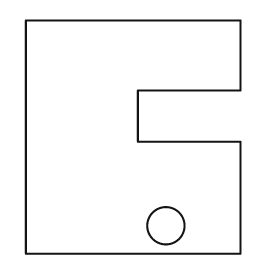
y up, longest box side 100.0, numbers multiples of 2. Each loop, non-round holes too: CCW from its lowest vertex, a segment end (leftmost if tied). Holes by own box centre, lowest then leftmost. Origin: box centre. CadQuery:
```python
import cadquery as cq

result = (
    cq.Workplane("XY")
    .moveTo(-46.0, -50.0)
    .lineTo(46.0, -50.0)
    .lineTo(46.0, -2.0)
    .lineTo(2.0, -2.0)
    .lineTo(2.0, 20.0)
    .lineTo(46.0, 20.0)
    .lineTo(46.0, 50.0)
    .lineTo(-46.0, 50.0)
    .close()
    .moveTo(14.0, -38.0)
    .circle(8.0)
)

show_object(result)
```